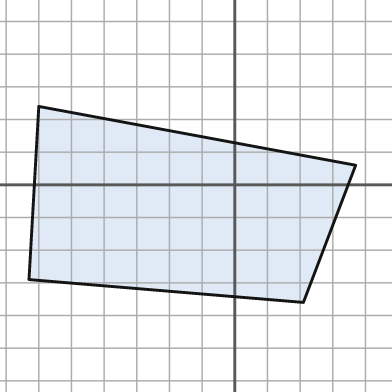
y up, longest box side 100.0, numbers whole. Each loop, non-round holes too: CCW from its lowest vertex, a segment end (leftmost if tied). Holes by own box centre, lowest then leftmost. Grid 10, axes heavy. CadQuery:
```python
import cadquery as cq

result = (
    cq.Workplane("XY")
    .moveTo(21.0, -36.0)
    .lineTo(37.0, 6.0)
    .lineTo(-60.0, 24.0)
    .lineTo(-63.0, -29.0)
    .close()
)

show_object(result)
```